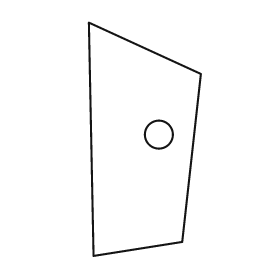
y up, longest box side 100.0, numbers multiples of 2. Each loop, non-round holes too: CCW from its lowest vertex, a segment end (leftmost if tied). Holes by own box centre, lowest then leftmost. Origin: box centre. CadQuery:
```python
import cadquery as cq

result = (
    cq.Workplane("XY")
    .moveTo(-22.0, -50.0)
    .lineTo(16.0, -44.0)
    .lineTo(24.0, 28.0)
    .lineTo(-24.0, 50.0)
    .close()
    .moveTo(6.0, 2.0)
    .circle(6.0)
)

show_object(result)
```